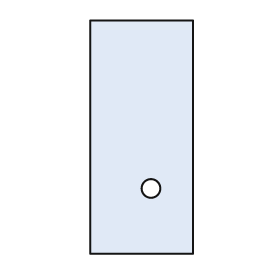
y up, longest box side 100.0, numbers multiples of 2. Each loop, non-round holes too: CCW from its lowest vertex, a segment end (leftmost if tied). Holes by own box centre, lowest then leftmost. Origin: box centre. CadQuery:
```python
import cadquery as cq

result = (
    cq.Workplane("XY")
    .moveTo(-22.0, -50.0)
    .lineTo(22.0, -50.0)
    .lineTo(22.0, 50.0)
    .lineTo(-22.0, 50.0)
    .close()
    .moveTo(4.0, -22.0)
    .circle(4.0)
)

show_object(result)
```